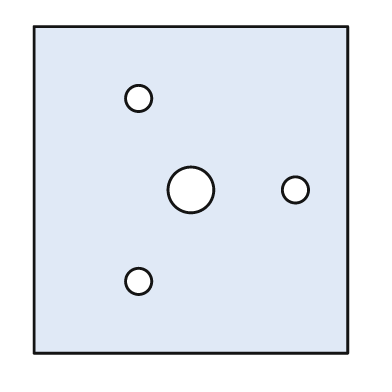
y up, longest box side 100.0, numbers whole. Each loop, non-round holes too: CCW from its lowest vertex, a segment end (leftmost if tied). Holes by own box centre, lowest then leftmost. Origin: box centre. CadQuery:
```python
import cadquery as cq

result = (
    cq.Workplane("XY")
    .moveTo(-48.0, -50.0)
    .lineTo(48.0, -50.0)
    .lineTo(48.0, 50.0)
    .lineTo(-48.0, 50.0)
    .close()
    .moveTo(-16.0, -28.0)
    .circle(4.0)
    .moveTo(0.0, 0.0)
    .circle(7.0)
    .moveTo(32.0, 0.0)
    .circle(4.0)
    .moveTo(-16.0, 28.0)
    .circle(4.0)
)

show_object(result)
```